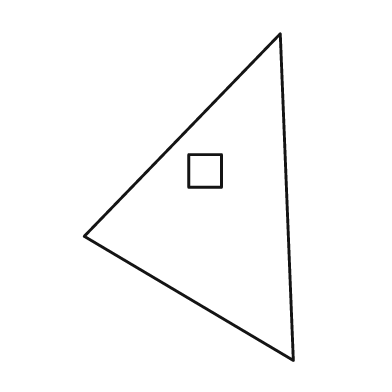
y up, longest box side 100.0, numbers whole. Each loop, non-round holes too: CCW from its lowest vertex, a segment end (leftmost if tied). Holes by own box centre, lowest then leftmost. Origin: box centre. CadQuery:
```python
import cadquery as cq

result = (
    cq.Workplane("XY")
    .moveTo(32.0, -50.0)
    .lineTo(28.0, 50.0)
    .lineTo(-32.0, -12.0)
    .close()
    .moveTo(0.0, 3.0)
    .lineTo(10.0, 3.0)
    .lineTo(10.0, 13.0)
    .lineTo(0.0, 13.0)
    .close()
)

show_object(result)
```